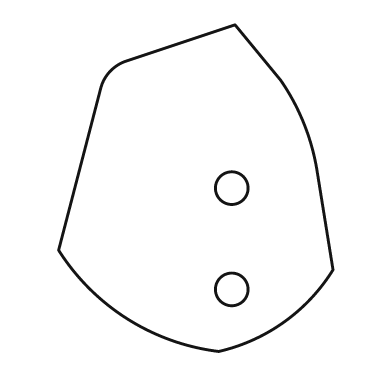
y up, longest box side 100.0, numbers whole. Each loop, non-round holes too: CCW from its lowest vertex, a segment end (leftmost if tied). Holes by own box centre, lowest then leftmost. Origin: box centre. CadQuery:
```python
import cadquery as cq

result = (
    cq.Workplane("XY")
    .moveTo(7.0, -50.0)
    .threePointArc((27.0, -41.0), (42.0, -25.0))
    .lineTo(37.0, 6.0)
    .threePointArc((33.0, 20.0), (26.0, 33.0))
    .lineTo(12.0, 50.0)
    .lineTo(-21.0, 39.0)
    .threePointArc((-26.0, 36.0), (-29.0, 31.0))
    .lineTo(-42.0, -19.0)
    .threePointArc((-21.0, -40.0), (7.0, -50.0))
    .close()
    .moveTo(11.0, -31.0)
    .circle(5.0)
    .moveTo(11.0, 0.0)
    .circle(5.0)
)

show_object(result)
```